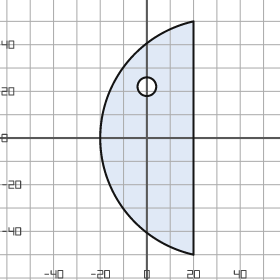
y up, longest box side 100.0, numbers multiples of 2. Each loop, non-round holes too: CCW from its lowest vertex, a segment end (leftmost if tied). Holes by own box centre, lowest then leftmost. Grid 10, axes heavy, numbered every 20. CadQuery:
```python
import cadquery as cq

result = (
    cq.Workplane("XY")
    .moveTo(20.0, -50.0)
    .lineTo(20.0, 50.0)
    .threePointArc((-20.0, 0.0), (20.0, -50.0))
    .close()
    .moveTo(0.0, 22.0)
    .circle(4.0)
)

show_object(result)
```